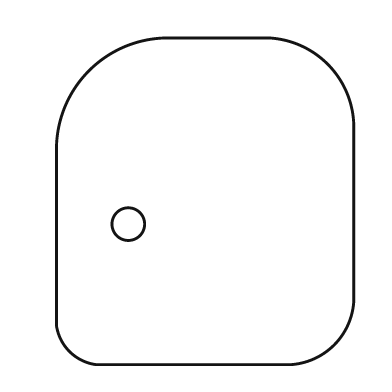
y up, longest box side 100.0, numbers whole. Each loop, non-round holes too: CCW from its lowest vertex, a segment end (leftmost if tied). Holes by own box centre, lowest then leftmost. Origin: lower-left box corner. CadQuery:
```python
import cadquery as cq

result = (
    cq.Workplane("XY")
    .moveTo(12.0, 0.0)
    .lineTo(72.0, 0.0)
    .threePointArc((85.0, 6.0), (91.0, 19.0))
    .lineTo(91.0, 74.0)
    .threePointArc((83.0, 92.0), (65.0, 100.0))
    .lineTo(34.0, 100.0)
    .threePointArc((10.0, 90.0), (0.0, 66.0))
    .lineTo(0.0, 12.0)
    .threePointArc((4.0, 4.0), (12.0, 0.0))
    .close()
    .moveTo(22.0, 43.0)
    .circle(5.0)
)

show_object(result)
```